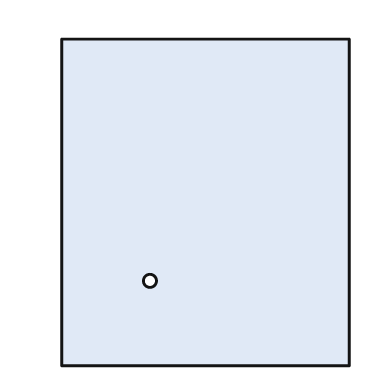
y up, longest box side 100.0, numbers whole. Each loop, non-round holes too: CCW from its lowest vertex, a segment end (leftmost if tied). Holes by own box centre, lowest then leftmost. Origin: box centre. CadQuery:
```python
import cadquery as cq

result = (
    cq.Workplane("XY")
    .moveTo(-44.0, -50.0)
    .lineTo(44.0, -50.0)
    .lineTo(44.0, 50.0)
    .lineTo(-44.0, 50.0)
    .close()
    .moveTo(-17.0, -24.0)
    .circle(2.0)
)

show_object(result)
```